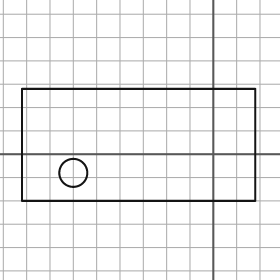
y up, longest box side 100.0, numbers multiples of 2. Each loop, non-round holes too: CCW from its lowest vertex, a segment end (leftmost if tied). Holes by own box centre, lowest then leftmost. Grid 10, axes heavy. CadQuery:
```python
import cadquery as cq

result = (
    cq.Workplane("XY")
    .moveTo(-82.0, -20.0)
    .lineTo(18.0, -20.0)
    .lineTo(18.0, 28.0)
    .lineTo(-82.0, 28.0)
    .close()
    .moveTo(-60.0, -8.0)
    .circle(6.0)
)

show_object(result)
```